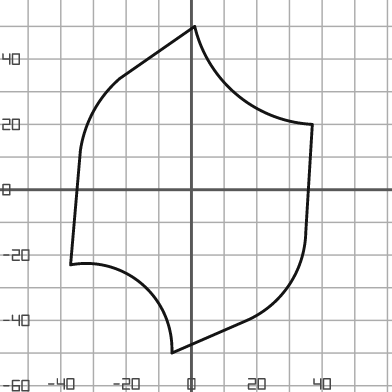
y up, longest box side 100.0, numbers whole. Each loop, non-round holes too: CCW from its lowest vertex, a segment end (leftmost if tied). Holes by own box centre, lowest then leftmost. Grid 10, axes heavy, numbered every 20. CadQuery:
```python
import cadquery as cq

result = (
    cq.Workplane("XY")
    .moveTo(-6.0, -50.0)
    .lineTo(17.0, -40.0)
    .threePointArc((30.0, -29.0), (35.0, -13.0))
    .lineTo(37.0, 20.0)
    .threePointArc((14.0, 29.0), (1.0, 50.0))
    .lineTo(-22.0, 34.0)
    .threePointArc((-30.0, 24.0), (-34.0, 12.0))
    .lineTo(-37.0, -23.0)
    .threePointArc((-15.0, -29.0), (-6.0, -50.0))
    .close()
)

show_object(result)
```